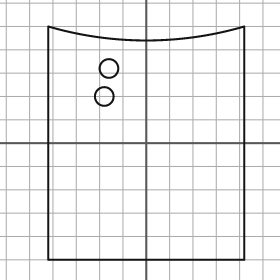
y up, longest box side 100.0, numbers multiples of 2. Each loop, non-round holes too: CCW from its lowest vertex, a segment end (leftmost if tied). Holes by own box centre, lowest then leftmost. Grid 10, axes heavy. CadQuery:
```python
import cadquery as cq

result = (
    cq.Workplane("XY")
    .moveTo(-42.0, -50.0)
    .lineTo(42.0, -50.0)
    .lineTo(42.0, 50.0)
    .threePointArc((0.0, 44.0), (-42.0, 50.0))
    .close()
    .moveTo(-18.0, 20.0)
    .circle(4.0)
    .moveTo(-16.0, 32.0)
    .circle(4.0)
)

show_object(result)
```